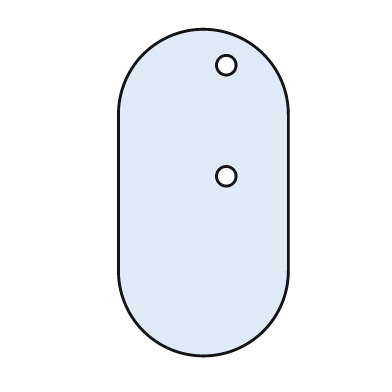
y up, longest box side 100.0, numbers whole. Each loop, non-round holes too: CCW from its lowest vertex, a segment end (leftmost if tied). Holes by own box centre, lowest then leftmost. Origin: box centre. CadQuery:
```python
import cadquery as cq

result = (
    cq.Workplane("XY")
    .moveTo(-26.0, -24.0)
    .threePointArc((0.0, -50.0), (26.0, -24.0))
    .lineTo(26.0, 24.0)
    .threePointArc((0.0, 50.0), (-26.0, 24.0))
    .close()
    .moveTo(7.0, 5.0)
    .circle(3.0)
    .moveTo(7.0, 39.0)
    .circle(3.0)
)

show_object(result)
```